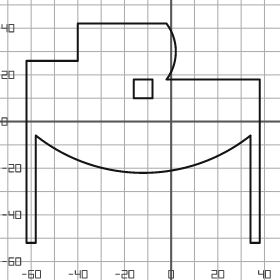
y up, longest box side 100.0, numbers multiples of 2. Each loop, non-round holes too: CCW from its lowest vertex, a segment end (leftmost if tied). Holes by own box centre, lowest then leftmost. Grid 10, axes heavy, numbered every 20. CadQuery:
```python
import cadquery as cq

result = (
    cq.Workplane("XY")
    .moveTo(-62.0, -52.0)
    .lineTo(-58.0, -52.0)
    .lineTo(-58.0, -6.0)
    .threePointArc((-12.0, -22.0), (34.0, -6.0))
    .lineTo(34.0, -52.0)
    .lineTo(38.0, -52.0)
    .lineTo(38.0, 18.0)
    .lineTo(-2.0, 18.0)
    .threePointArc((2.0, 30.0), (-2.0, 42.0))
    .lineTo(-40.0, 42.0)
    .lineTo(-40.0, 26.0)
    .lineTo(-62.0, 26.0)
    .close()
    .moveTo(-16.0, 10.0)
    .lineTo(-8.0, 10.0)
    .lineTo(-8.0, 18.0)
    .lineTo(-16.0, 18.0)
    .close()
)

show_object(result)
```